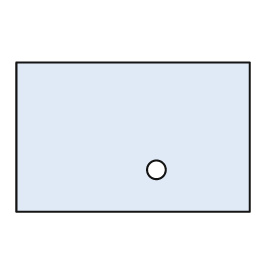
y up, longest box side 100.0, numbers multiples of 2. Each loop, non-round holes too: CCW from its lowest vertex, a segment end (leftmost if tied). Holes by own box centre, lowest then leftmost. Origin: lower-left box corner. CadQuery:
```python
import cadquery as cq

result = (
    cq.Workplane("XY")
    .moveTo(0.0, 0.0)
    .lineTo(100.0, 0.0)
    .lineTo(100.0, 64.0)
    .lineTo(0.0, 64.0)
    .close()
    .moveTo(60.0, 18.0)
    .circle(4.0)
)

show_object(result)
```